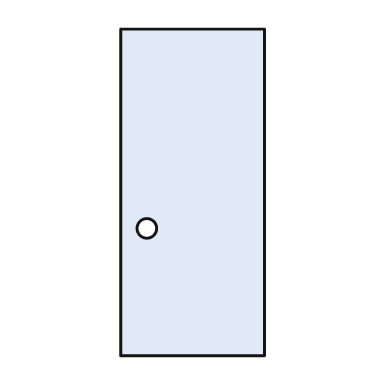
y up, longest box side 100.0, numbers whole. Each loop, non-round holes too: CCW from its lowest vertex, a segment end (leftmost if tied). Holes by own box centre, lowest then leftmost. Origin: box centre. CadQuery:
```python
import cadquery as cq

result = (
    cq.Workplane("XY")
    .moveTo(-22.0, -50.0)
    .lineTo(22.0, -50.0)
    .lineTo(22.0, 50.0)
    .lineTo(-22.0, 50.0)
    .close()
    .moveTo(-14.0, -11.0)
    .circle(3.0)
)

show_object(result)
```